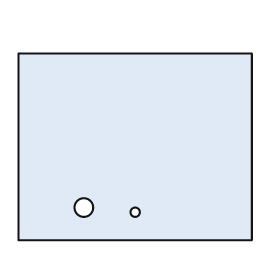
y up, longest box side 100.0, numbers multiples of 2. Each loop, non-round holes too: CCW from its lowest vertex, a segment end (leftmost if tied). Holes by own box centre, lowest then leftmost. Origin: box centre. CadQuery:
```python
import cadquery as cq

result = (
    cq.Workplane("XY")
    .moveTo(-50.0, -40.0)
    .lineTo(50.0, -40.0)
    .lineTo(50.0, 40.0)
    .lineTo(-50.0, 40.0)
    .close()
    .moveTo(0.0, -28.0)
    .circle(2.0)
    .moveTo(-22.0, -26.0)
    .circle(4.0)
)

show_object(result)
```